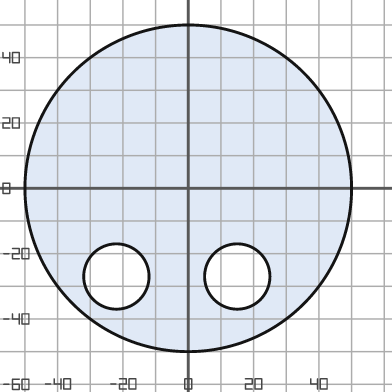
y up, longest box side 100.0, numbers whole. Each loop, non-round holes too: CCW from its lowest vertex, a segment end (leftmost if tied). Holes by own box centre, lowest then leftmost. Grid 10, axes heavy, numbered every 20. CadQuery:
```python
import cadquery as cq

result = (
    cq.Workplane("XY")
    .moveTo(0.0, 0.0)
    .circle(50.0)
    .moveTo(-22.0, -27.0)
    .circle(10.0)
    .moveTo(15.0, -27.0)
    .circle(10.0)
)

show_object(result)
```